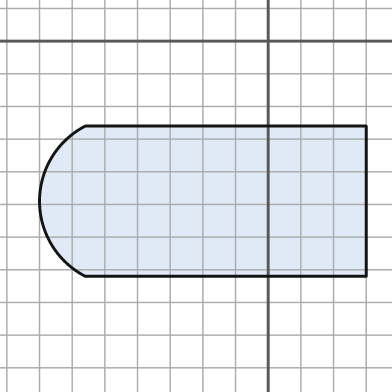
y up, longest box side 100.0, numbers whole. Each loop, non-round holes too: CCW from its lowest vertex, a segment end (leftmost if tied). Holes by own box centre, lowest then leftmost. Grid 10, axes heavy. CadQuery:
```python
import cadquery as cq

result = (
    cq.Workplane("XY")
    .moveTo(-56.0, -72.0)
    .lineTo(30.0, -72.0)
    .lineTo(30.0, -26.0)
    .lineTo(-56.0, -26.0)
    .threePointArc((-70.0, -49.0), (-56.0, -72.0))
    .close()
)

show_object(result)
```